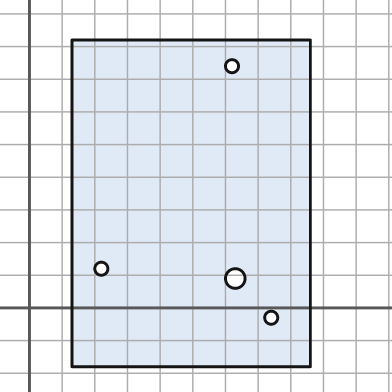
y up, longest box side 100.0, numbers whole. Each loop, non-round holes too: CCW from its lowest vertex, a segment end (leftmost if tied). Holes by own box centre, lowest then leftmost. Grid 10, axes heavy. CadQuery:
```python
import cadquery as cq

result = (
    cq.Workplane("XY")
    .moveTo(13.0, -18.0)
    .lineTo(86.0, -18.0)
    .lineTo(86.0, 82.0)
    .lineTo(13.0, 82.0)
    .close()
    .moveTo(74.0, -3.0)
    .circle(2.0)
    .moveTo(63.0, 9.0)
    .circle(3.0)
    .moveTo(22.0, 12.0)
    .circle(2.0)
    .moveTo(62.0, 74.0)
    .circle(2.0)
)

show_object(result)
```